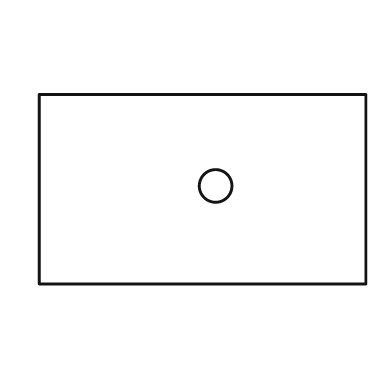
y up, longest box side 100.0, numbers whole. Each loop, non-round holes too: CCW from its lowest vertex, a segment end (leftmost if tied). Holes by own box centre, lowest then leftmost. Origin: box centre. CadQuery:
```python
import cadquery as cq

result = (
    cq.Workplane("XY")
    .moveTo(-50.0, -29.0)
    .lineTo(50.0, -29.0)
    .lineTo(50.0, 29.0)
    .lineTo(-50.0, 29.0)
    .close()
    .moveTo(4.0, 1.0)
    .circle(5.0)
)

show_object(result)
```